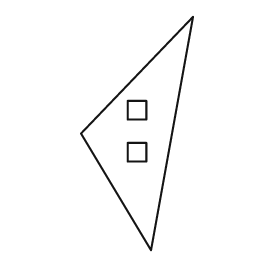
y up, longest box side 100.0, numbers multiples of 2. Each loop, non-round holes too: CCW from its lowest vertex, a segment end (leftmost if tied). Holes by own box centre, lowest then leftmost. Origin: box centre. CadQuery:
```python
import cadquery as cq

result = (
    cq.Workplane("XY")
    .moveTo(6.0, -50.0)
    .lineTo(24.0, 50.0)
    .lineTo(-24.0, 0.0)
    .close()
    .moveTo(-4.0, -12.0)
    .lineTo(4.0, -12.0)
    .lineTo(4.0, -4.0)
    .lineTo(-4.0, -4.0)
    .close()
    .moveTo(-4.0, 6.0)
    .lineTo(4.0, 6.0)
    .lineTo(4.0, 14.0)
    .lineTo(-4.0, 14.0)
    .close()
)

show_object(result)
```